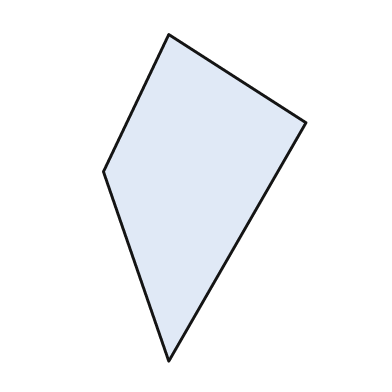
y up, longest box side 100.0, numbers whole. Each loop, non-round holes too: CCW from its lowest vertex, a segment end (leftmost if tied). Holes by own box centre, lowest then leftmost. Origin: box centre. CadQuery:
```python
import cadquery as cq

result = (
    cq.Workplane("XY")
    .moveTo(-11.0, -50.0)
    .lineTo(31.0, 23.0)
    .lineTo(-11.0, 50.0)
    .lineTo(-31.0, 8.0)
    .close()
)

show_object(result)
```